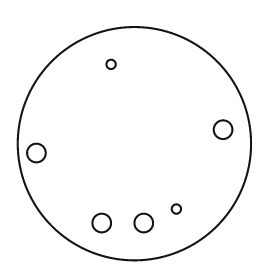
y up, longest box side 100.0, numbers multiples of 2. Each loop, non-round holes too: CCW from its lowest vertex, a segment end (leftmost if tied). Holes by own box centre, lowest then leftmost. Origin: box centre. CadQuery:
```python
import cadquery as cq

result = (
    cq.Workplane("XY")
    .moveTo(0.0, 0.0)
    .circle(50.0)
    .moveTo(-14.0, -34.0)
    .circle(4.0)
    .moveTo(4.0, -34.0)
    .circle(4.0)
    .moveTo(18.0, -28.0)
    .circle(2.0)
    .moveTo(-42.0, -4.0)
    .circle(4.0)
    .moveTo(38.0, 6.0)
    .circle(4.0)
    .moveTo(-10.0, 34.0)
    .circle(2.0)
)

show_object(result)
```